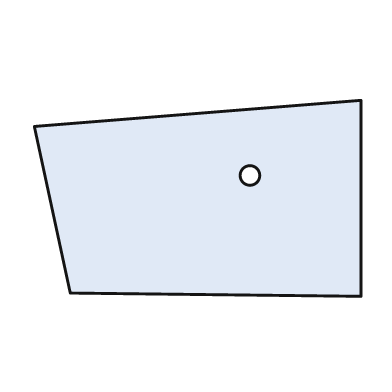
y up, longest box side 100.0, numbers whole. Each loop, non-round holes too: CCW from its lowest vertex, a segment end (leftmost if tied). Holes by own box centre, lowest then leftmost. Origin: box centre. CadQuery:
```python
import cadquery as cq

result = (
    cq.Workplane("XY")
    .moveTo(50.0, -30.0)
    .lineTo(50.0, 30.0)
    .lineTo(-50.0, 22.0)
    .lineTo(-39.0, -29.0)
    .close()
    .moveTo(16.0, 7.0)
    .circle(3.0)
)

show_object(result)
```